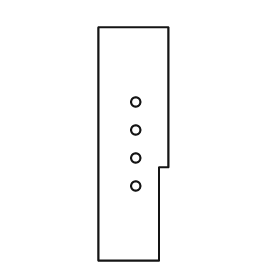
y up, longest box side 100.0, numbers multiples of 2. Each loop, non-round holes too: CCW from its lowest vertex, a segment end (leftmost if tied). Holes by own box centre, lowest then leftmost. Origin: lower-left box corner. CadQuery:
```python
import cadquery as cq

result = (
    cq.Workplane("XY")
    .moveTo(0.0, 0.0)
    .lineTo(26.0, 0.0)
    .lineTo(26.0, 40.0)
    .lineTo(30.0, 40.0)
    .lineTo(30.0, 100.0)
    .lineTo(0.0, 100.0)
    .close()
    .moveTo(16.0, 32.0)
    .circle(2.0)
    .moveTo(16.0, 44.0)
    .circle(2.0)
    .moveTo(16.0, 56.0)
    .circle(2.0)
    .moveTo(16.0, 68.0)
    .circle(2.0)
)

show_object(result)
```